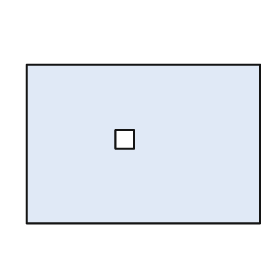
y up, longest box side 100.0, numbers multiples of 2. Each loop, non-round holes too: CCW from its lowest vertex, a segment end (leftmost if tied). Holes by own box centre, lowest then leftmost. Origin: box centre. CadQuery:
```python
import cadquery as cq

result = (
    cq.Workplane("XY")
    .moveTo(-50.0, -34.0)
    .lineTo(50.0, -34.0)
    .lineTo(50.0, 34.0)
    .lineTo(-50.0, 34.0)
    .close()
    .moveTo(-12.0, -2.0)
    .lineTo(-4.0, -2.0)
    .lineTo(-4.0, 6.0)
    .lineTo(-12.0, 6.0)
    .close()
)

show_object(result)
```